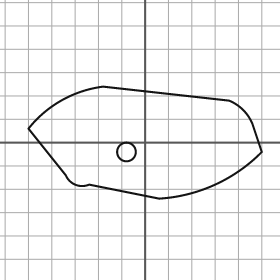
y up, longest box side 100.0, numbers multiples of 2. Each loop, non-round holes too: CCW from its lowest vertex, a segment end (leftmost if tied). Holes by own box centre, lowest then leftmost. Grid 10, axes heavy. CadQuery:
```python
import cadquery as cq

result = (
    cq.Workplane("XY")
    .moveTo(6.0, -24.0)
    .threePointArc((30.0, -18.0), (50.0, -4.0))
    .lineTo(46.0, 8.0)
    .threePointArc((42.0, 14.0), (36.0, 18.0))
    .lineTo(-18.0, 24.0)
    .threePointArc((-36.0, 18.0), (-50.0, 6.0))
    .lineTo(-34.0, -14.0)
    .threePointArc((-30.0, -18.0), (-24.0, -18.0))
    .close()
    .moveTo(-8.0, -4.0)
    .circle(4.0)
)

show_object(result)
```